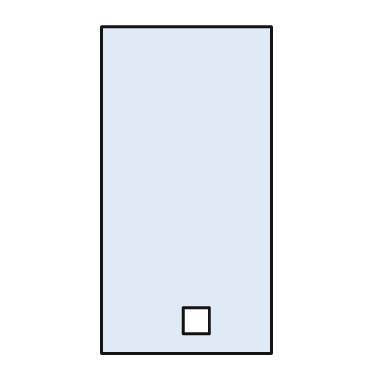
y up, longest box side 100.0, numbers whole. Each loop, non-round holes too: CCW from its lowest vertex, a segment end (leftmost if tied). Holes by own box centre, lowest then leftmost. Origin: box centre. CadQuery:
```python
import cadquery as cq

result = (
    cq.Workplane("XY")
    .moveTo(-26.0, -50.0)
    .lineTo(26.0, -50.0)
    .lineTo(26.0, 50.0)
    .lineTo(-26.0, 50.0)
    .close()
    .moveTo(-1.0, -44.0)
    .lineTo(7.0, -44.0)
    .lineTo(7.0, -36.0)
    .lineTo(-1.0, -36.0)
    .close()
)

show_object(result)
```